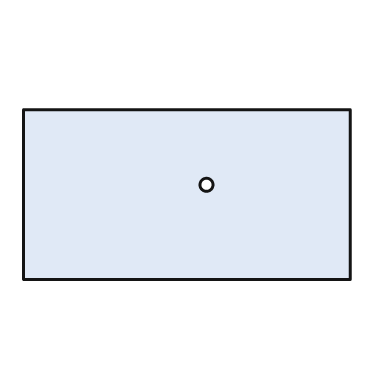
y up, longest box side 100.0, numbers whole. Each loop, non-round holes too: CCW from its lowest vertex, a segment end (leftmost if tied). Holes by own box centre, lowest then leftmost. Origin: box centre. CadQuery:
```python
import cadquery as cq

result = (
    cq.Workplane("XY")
    .moveTo(-50.0, -26.0)
    .lineTo(50.0, -26.0)
    .lineTo(50.0, 26.0)
    .lineTo(-50.0, 26.0)
    .close()
    .moveTo(6.0, 3.0)
    .circle(2.0)
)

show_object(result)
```